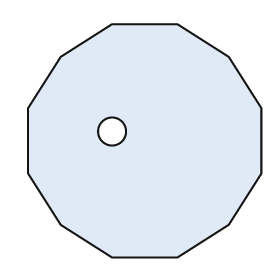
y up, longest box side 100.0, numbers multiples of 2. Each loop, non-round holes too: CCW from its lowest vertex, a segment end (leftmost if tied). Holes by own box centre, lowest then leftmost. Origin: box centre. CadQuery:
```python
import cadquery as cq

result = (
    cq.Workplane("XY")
    .moveTo(-14.0, -50.0)
    .lineTo(14.0, -50.0)
    .lineTo(36.0, -36.0)
    .lineTo(50.0, -14.0)
    .lineTo(50.0, 14.0)
    .lineTo(36.0, 36.0)
    .lineTo(14.0, 50.0)
    .lineTo(-14.0, 50.0)
    .lineTo(-36.0, 36.0)
    .lineTo(-50.0, 14.0)
    .lineTo(-50.0, -14.0)
    .lineTo(-36.0, -36.0)
    .close()
    .moveTo(-14.0, 4.0)
    .circle(6.0)
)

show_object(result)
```